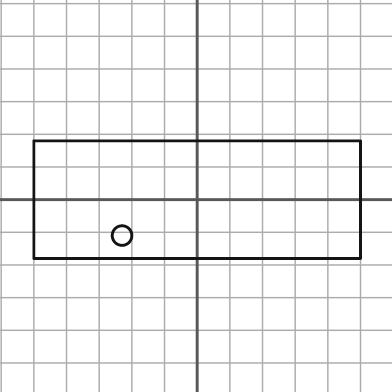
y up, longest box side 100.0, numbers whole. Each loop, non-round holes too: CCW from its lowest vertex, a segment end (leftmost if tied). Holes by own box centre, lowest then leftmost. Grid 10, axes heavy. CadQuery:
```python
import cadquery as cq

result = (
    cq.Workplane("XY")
    .moveTo(-50.0, -18.0)
    .lineTo(50.0, -18.0)
    .lineTo(50.0, 18.0)
    .lineTo(-50.0, 18.0)
    .close()
    .moveTo(-23.0, -11.0)
    .circle(3.0)
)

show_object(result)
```